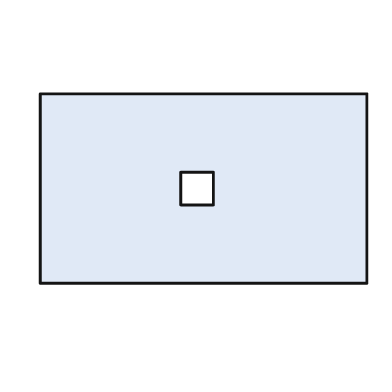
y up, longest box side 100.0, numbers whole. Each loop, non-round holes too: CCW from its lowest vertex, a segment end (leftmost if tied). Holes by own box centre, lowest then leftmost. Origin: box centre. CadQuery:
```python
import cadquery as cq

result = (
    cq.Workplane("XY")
    .moveTo(-50.0, -29.0)
    .lineTo(50.0, -29.0)
    .lineTo(50.0, 29.0)
    .lineTo(-50.0, 29.0)
    .close()
    .moveTo(-7.0, -5.0)
    .lineTo(3.0, -5.0)
    .lineTo(3.0, 5.0)
    .lineTo(-7.0, 5.0)
    .close()
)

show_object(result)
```